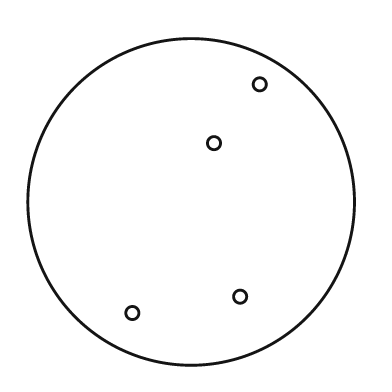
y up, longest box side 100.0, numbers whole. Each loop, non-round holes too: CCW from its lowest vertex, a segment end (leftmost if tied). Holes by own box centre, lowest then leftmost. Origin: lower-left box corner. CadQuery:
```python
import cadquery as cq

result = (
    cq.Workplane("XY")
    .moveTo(50.0, 50.0)
    .circle(50.0)
    .moveTo(32.0, 16.0)
    .circle(2.0)
    .moveTo(65.0, 21.0)
    .circle(2.0)
    .moveTo(57.0, 68.0)
    .circle(2.0)
    .moveTo(71.0, 86.0)
    .circle(2.0)
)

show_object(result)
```